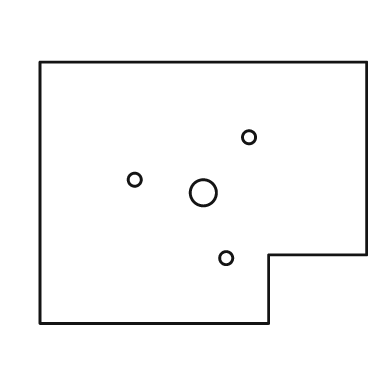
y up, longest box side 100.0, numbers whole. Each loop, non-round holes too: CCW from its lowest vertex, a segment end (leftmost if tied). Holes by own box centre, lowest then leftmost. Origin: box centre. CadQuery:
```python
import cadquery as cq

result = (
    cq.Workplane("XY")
    .moveTo(-50.0, -40.0)
    .lineTo(20.0, -40.0)
    .lineTo(20.0, -19.0)
    .lineTo(50.0, -19.0)
    .lineTo(50.0, 40.0)
    .lineTo(-50.0, 40.0)
    .close()
    .moveTo(7.0, -20.0)
    .circle(2.0)
    .moveTo(0.0, 0.0)
    .circle(4.0)
    .moveTo(-21.0, 4.0)
    .circle(2.0)
    .moveTo(14.0, 17.0)
    .circle(2.0)
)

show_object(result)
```